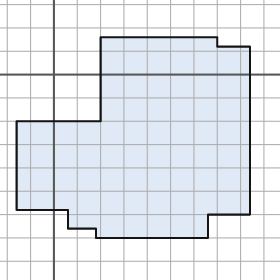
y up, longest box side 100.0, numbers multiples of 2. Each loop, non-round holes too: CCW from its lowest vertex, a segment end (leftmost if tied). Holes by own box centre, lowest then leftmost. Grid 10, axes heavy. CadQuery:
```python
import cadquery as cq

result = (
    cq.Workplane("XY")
    .moveTo(18.0, -70.0)
    .lineTo(66.0, -70.0)
    .lineTo(66.0, -60.0)
    .lineTo(84.0, -60.0)
    .lineTo(84.0, 12.0)
    .lineTo(70.0, 12.0)
    .lineTo(70.0, 16.0)
    .lineTo(20.0, 16.0)
    .lineTo(20.0, -20.0)
    .lineTo(-16.0, -20.0)
    .lineTo(-16.0, -58.0)
    .lineTo(6.0, -58.0)
    .lineTo(6.0, -66.0)
    .lineTo(18.0, -66.0)
    .close()
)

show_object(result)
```